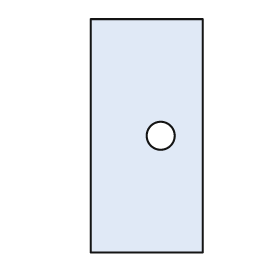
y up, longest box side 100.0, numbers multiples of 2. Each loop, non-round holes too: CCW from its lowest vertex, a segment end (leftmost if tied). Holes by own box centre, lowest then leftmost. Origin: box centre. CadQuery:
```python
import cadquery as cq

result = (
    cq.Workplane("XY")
    .moveTo(-24.0, -50.0)
    .lineTo(24.0, -50.0)
    .lineTo(24.0, 50.0)
    .lineTo(-24.0, 50.0)
    .close()
    .moveTo(6.0, 0.0)
    .circle(6.0)
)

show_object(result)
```